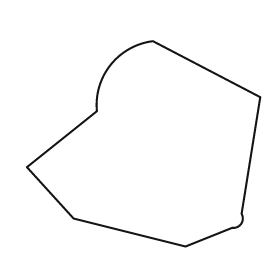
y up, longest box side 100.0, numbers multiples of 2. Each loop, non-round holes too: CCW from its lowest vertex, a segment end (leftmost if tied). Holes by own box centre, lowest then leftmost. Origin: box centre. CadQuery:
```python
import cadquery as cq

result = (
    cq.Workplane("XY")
    .moveTo(18.0, -44.0)
    .lineTo(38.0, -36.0)
    .threePointArc((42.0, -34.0), (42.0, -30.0))
    .lineTo(50.0, 20.0)
    .lineTo(4.0, 44.0)
    .threePointArc((-14.0, 34.0), (-20.0, 14.0))
    .lineTo(-50.0, -10.0)
    .lineTo(-30.0, -32.0)
    .close()
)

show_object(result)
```